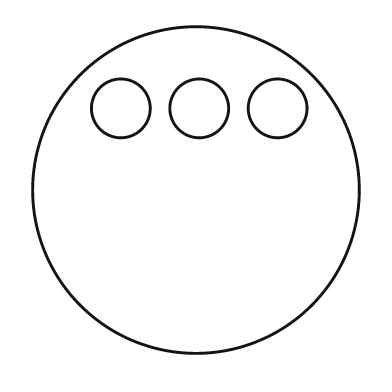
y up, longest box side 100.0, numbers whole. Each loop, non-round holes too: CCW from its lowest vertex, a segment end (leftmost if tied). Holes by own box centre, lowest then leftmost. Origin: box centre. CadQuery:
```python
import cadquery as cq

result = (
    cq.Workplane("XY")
    .moveTo(0.0, 0.0)
    .circle(50.0)
    .moveTo(-23.0, 25.0)
    .circle(9.0)
    .moveTo(1.0, 25.0)
    .circle(9.0)
    .moveTo(25.0, 25.0)
    .circle(9.0)
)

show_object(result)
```